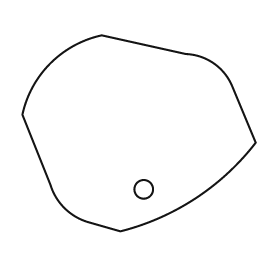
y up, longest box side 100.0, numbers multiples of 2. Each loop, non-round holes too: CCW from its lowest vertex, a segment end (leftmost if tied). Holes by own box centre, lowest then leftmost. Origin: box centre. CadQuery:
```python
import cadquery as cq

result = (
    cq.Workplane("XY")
    .moveTo(-8.0, -42.0)
    .threePointArc((24.0, -28.0), (50.0, -4.0))
    .lineTo(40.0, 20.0)
    .threePointArc((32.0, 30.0), (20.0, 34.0))
    .lineTo(-16.0, 42.0)
    .threePointArc((-38.0, 30.0), (-50.0, 8.0))
    .lineTo(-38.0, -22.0)
    .threePointArc((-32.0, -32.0), (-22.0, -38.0))
    .close()
    .moveTo(2.0, -24.0)
    .circle(4.0)
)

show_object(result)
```